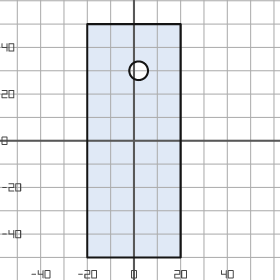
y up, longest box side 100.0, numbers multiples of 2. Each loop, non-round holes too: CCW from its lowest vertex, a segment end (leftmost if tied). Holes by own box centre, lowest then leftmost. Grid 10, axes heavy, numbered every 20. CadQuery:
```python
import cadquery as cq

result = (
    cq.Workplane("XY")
    .moveTo(-20.0, -50.0)
    .lineTo(20.0, -50.0)
    .lineTo(20.0, 50.0)
    .lineTo(-20.0, 50.0)
    .close()
    .moveTo(2.0, 30.0)
    .circle(4.0)
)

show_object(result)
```